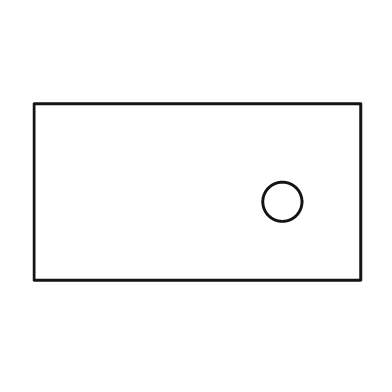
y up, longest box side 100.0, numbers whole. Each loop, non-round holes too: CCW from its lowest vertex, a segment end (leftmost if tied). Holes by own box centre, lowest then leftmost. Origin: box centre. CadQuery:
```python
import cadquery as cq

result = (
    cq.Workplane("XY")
    .moveTo(-50.0, -27.0)
    .lineTo(50.0, -27.0)
    .lineTo(50.0, 27.0)
    .lineTo(-50.0, 27.0)
    .close()
    .moveTo(26.0, -3.0)
    .circle(6.0)
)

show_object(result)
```